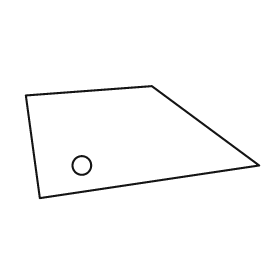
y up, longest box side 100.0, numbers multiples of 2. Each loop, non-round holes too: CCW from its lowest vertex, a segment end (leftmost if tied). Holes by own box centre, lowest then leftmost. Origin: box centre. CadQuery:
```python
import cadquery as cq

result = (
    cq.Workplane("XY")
    .moveTo(-44.0, -24.0)
    .lineTo(50.0, -10.0)
    .lineTo(4.0, 24.0)
    .lineTo(-50.0, 20.0)
    .close()
    .moveTo(-26.0, -10.0)
    .circle(4.0)
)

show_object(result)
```